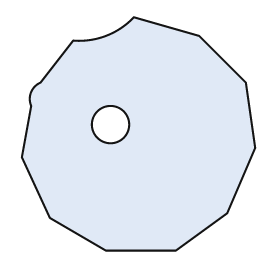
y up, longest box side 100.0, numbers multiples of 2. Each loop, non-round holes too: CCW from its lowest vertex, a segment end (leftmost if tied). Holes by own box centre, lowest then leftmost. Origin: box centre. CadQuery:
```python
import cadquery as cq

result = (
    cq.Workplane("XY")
    .moveTo(-14.0, -50.0)
    .lineTo(16.0, -50.0)
    .lineTo(38.0, -34.0)
    .lineTo(50.0, -6.0)
    .lineTo(46.0, 22.0)
    .lineTo(26.0, 42.0)
    .lineTo(-2.0, 50.0)
    .threePointArc((-14.0, 42.0), (-28.0, 40.0))
    .lineTo(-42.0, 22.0)
    .threePointArc((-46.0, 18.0), (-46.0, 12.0))
    .lineTo(-50.0, -10.0)
    .lineTo(-38.0, -36.0)
    .close()
    .moveTo(-12.0, 4.0)
    .circle(8.0)
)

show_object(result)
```